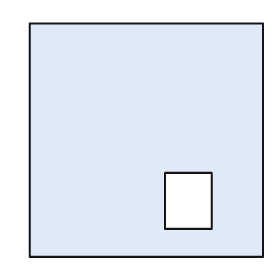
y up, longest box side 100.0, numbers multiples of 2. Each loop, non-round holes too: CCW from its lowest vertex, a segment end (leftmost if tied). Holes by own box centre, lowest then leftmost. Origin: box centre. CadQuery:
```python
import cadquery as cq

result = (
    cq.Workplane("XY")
    .moveTo(-50.0, -50.0)
    .lineTo(50.0, -50.0)
    .lineTo(50.0, 50.0)
    .lineTo(-50.0, 50.0)
    .close()
    .moveTo(8.0, -38.0)
    .lineTo(28.0, -38.0)
    .lineTo(28.0, -14.0)
    .lineTo(8.0, -14.0)
    .close()
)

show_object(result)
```